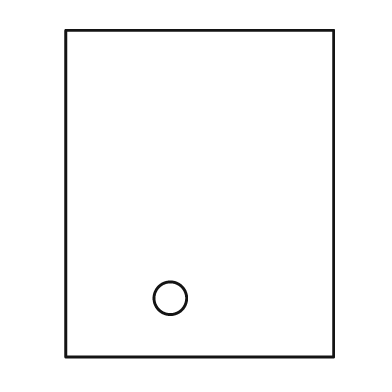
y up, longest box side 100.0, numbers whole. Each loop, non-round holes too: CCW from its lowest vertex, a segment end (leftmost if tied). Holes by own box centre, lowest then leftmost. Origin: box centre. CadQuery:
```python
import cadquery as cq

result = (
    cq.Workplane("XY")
    .moveTo(-41.0, -50.0)
    .lineTo(41.0, -50.0)
    .lineTo(41.0, 50.0)
    .lineTo(-41.0, 50.0)
    .close()
    .moveTo(-9.0, -32.0)
    .circle(5.0)
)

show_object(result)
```